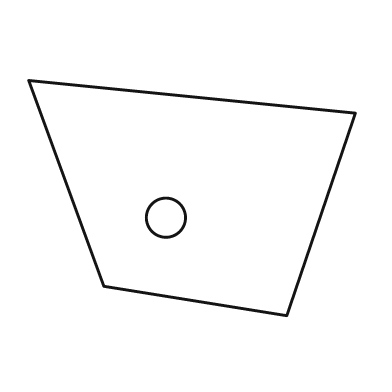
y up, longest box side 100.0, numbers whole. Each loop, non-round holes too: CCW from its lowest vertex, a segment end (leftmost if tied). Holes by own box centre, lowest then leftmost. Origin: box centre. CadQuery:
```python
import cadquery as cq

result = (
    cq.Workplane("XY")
    .moveTo(29.0, -36.0)
    .lineTo(50.0, 26.0)
    .lineTo(-50.0, 36.0)
    .lineTo(-27.0, -27.0)
    .close()
    .moveTo(-8.0, -6.0)
    .circle(6.0)
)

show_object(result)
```